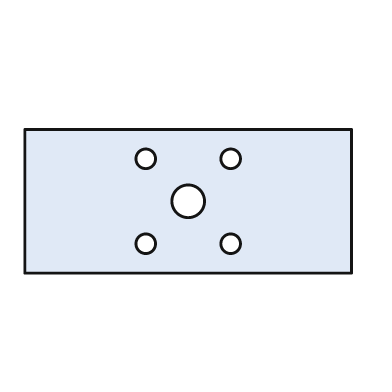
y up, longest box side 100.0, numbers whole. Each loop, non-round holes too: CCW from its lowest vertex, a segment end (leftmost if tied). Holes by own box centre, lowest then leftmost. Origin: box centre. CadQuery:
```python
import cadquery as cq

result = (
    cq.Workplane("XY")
    .moveTo(-50.0, -22.0)
    .lineTo(50.0, -22.0)
    .lineTo(50.0, 22.0)
    .lineTo(-50.0, 22.0)
    .close()
    .moveTo(-13.0, -13.0)
    .circle(3.0)
    .moveTo(13.0, -13.0)
    .circle(3.0)
    .moveTo(0.0, 0.0)
    .circle(5.0)
    .moveTo(-13.0, 13.0)
    .circle(3.0)
    .moveTo(13.0, 13.0)
    .circle(3.0)
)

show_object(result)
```